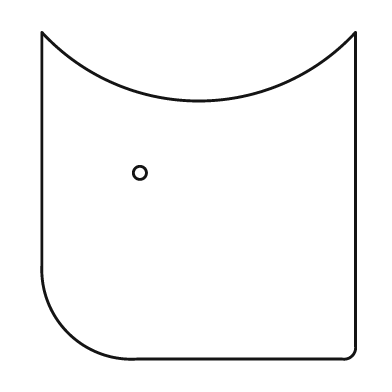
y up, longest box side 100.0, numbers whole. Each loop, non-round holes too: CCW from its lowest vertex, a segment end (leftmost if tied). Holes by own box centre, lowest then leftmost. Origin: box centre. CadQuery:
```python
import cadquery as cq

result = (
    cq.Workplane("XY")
    .moveTo(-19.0, -50.0)
    .lineTo(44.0, -50.0)
    .threePointArc((47.0, -49.0), (48.0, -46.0))
    .lineTo(48.0, 50.0)
    .threePointArc((0.0, 29.0), (-48.0, 50.0))
    .lineTo(-48.0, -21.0)
    .threePointArc((-40.0, -42.0), (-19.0, -50.0))
    .close()
    .moveTo(-18.0, 7.0)
    .circle(2.0)
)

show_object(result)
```